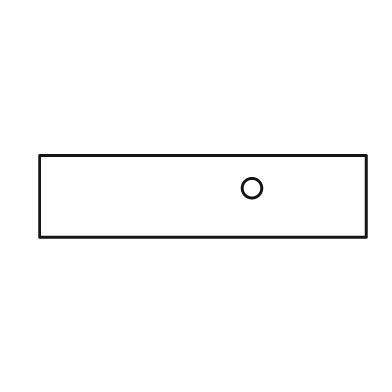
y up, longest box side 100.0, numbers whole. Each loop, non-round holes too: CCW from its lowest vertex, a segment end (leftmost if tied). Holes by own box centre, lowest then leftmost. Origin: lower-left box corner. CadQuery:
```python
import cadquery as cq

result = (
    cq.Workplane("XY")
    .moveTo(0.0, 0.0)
    .lineTo(100.0, 0.0)
    .lineTo(100.0, 25.0)
    .lineTo(0.0, 25.0)
    .close()
    .moveTo(65.0, 15.0)
    .circle(3.0)
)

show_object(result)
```